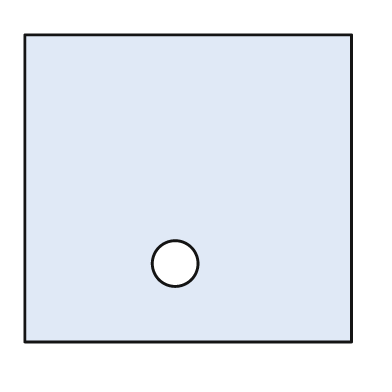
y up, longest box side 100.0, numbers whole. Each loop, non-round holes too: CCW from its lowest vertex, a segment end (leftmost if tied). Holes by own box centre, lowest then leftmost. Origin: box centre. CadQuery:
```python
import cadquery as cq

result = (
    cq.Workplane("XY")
    .moveTo(-50.0, -47.0)
    .lineTo(50.0, -47.0)
    .lineTo(50.0, 47.0)
    .lineTo(-50.0, 47.0)
    .close()
    .moveTo(-4.0, -23.0)
    .circle(7.0)
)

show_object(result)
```